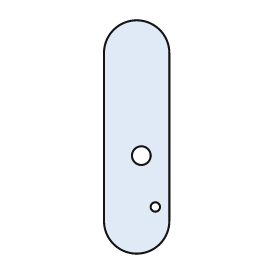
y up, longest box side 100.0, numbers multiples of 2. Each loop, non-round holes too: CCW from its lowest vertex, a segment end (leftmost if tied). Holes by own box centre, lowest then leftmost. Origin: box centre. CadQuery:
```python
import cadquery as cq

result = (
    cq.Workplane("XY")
    .moveTo(-14.0, -36.0)
    .threePointArc((0.0, -50.0), (14.0, -36.0))
    .lineTo(14.0, 36.0)
    .threePointArc((0.0, 50.0), (-14.0, 36.0))
    .close()
    .moveTo(8.0, -30.0)
    .circle(2.0)
    .moveTo(2.0, -8.0)
    .circle(4.0)
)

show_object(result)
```